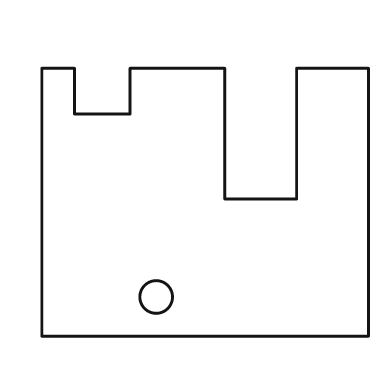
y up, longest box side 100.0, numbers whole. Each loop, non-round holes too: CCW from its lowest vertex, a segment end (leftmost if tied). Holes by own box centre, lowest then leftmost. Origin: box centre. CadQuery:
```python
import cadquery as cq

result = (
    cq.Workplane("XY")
    .moveTo(-50.0, -41.0)
    .lineTo(50.0, -41.0)
    .lineTo(50.0, 41.0)
    .lineTo(28.0, 41.0)
    .lineTo(28.0, 1.0)
    .lineTo(6.0, 1.0)
    .lineTo(6.0, 41.0)
    .lineTo(-23.0, 41.0)
    .lineTo(-23.0, 27.0)
    .lineTo(-40.0, 27.0)
    .lineTo(-40.0, 41.0)
    .lineTo(-50.0, 41.0)
    .close()
    .moveTo(-15.0, -29.0)
    .circle(5.0)
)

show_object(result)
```